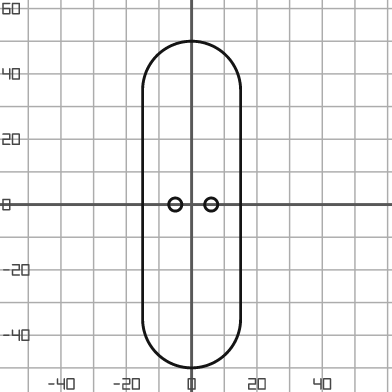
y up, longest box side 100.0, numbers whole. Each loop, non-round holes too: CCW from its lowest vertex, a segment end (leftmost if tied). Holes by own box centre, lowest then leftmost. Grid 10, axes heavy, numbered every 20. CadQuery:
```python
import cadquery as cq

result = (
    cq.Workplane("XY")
    .moveTo(-15.0, -35.0)
    .threePointArc((0.0, -50.0), (15.0, -35.0))
    .lineTo(15.0, 35.0)
    .threePointArc((0.0, 50.0), (-15.0, 35.0))
    .close()
    .moveTo(-5.0, 0.0)
    .circle(2.0)
    .moveTo(6.0, 0.0)
    .circle(2.0)
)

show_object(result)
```